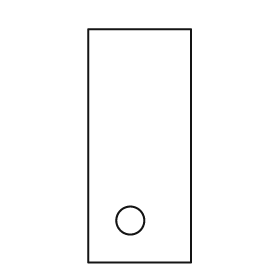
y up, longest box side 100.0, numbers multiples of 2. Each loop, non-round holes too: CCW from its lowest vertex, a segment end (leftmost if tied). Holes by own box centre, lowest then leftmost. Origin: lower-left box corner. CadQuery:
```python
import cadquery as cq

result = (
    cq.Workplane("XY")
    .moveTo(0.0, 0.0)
    .lineTo(44.0, 0.0)
    .lineTo(44.0, 100.0)
    .lineTo(0.0, 100.0)
    .close()
    .moveTo(18.0, 18.0)
    .circle(6.0)
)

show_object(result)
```